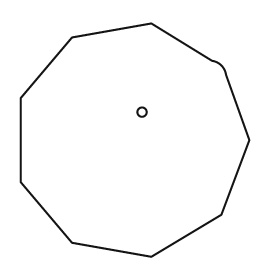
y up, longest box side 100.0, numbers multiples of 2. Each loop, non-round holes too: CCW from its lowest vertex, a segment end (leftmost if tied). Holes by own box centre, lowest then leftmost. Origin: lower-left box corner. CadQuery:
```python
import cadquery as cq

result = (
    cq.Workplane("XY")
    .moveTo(56.0, 0.0)
    .lineTo(86.0, 18.0)
    .lineTo(98.0, 50.0)
    .lineTo(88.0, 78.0)
    .threePointArc((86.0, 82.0), (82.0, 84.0))
    .lineTo(56.0, 100.0)
    .lineTo(22.0, 94.0)
    .lineTo(0.0, 68.0)
    .lineTo(0.0, 32.0)
    .lineTo(22.0, 6.0)
    .close()
    .moveTo(52.0, 62.0)
    .circle(2.0)
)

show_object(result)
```